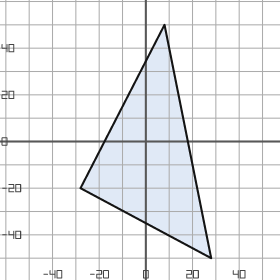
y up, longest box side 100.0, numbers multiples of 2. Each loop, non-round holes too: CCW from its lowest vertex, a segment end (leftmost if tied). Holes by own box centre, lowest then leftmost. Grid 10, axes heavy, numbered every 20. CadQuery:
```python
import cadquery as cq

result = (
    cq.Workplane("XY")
    .moveTo(28.0, -50.0)
    .lineTo(8.0, 50.0)
    .lineTo(-28.0, -20.0)
    .close()
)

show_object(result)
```